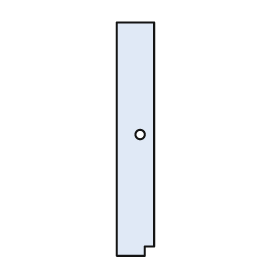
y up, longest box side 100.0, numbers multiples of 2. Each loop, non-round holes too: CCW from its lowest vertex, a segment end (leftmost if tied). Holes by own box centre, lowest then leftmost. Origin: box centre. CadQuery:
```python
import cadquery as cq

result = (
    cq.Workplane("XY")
    .moveTo(-8.0, -50.0)
    .lineTo(4.0, -50.0)
    .lineTo(4.0, -46.0)
    .lineTo(8.0, -46.0)
    .lineTo(8.0, 50.0)
    .lineTo(-8.0, 50.0)
    .close()
    .moveTo(2.0, 2.0)
    .circle(2.0)
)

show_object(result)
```